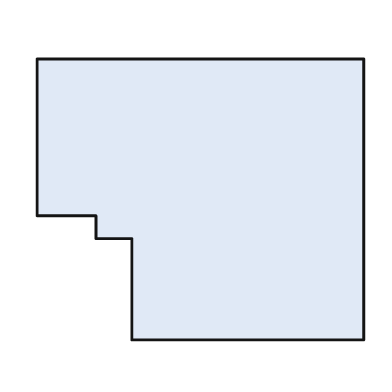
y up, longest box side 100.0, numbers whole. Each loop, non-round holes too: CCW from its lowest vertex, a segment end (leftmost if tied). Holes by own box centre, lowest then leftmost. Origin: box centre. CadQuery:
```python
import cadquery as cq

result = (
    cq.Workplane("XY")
    .moveTo(-21.0, -43.0)
    .lineTo(50.0, -43.0)
    .lineTo(50.0, 43.0)
    .lineTo(-50.0, 43.0)
    .lineTo(-50.0, -5.0)
    .lineTo(-32.0, -5.0)
    .lineTo(-32.0, -12.0)
    .lineTo(-21.0, -12.0)
    .close()
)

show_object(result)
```